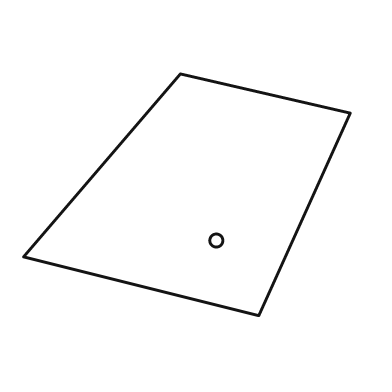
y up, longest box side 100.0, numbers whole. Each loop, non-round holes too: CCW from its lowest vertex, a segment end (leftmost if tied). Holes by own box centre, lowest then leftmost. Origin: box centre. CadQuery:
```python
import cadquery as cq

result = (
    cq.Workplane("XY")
    .moveTo(22.0, -37.0)
    .lineTo(50.0, 25.0)
    .lineTo(-2.0, 37.0)
    .lineTo(-50.0, -19.0)
    .close()
    .moveTo(9.0, -14.0)
    .circle(2.0)
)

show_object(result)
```